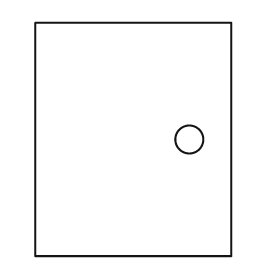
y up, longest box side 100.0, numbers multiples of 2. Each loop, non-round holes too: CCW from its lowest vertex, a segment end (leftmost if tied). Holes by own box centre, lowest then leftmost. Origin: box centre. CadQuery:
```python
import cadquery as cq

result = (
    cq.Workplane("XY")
    .moveTo(-42.0, -50.0)
    .lineTo(42.0, -50.0)
    .lineTo(42.0, 50.0)
    .lineTo(-42.0, 50.0)
    .close()
    .moveTo(24.0, 0.0)
    .circle(6.0)
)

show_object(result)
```